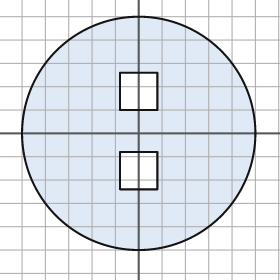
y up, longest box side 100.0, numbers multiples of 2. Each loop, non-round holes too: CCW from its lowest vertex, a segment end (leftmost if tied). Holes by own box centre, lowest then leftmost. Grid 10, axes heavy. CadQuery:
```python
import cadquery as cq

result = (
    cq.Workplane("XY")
    .moveTo(0.0, 0.0)
    .circle(50.0)
    .moveTo(-8.0, -24.0)
    .lineTo(8.0, -24.0)
    .lineTo(8.0, -8.0)
    .lineTo(-8.0, -8.0)
    .close()
    .moveTo(-8.0, 10.0)
    .lineTo(8.0, 10.0)
    .lineTo(8.0, 26.0)
    .lineTo(-8.0, 26.0)
    .close()
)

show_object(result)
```